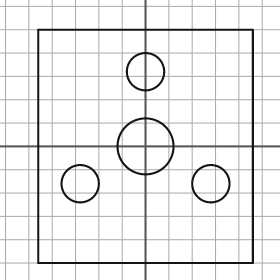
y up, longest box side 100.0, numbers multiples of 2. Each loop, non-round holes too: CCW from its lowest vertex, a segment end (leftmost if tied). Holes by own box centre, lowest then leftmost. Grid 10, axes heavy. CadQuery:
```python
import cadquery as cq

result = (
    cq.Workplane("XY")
    .moveTo(-46.0, -50.0)
    .lineTo(46.0, -50.0)
    .lineTo(46.0, 50.0)
    .lineTo(-46.0, 50.0)
    .close()
    .moveTo(-28.0, -16.0)
    .circle(8.0)
    .moveTo(28.0, -16.0)
    .circle(8.0)
    .moveTo(0.0, 0.0)
    .circle(12.0)
    .moveTo(0.0, 32.0)
    .circle(8.0)
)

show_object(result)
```